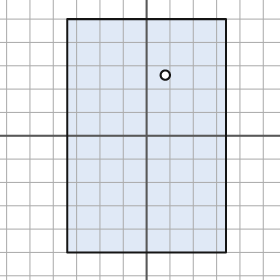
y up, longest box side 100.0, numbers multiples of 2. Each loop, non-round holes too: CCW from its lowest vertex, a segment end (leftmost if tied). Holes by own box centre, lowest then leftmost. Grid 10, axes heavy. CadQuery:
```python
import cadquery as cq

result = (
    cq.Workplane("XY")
    .moveTo(-34.0, -50.0)
    .lineTo(34.0, -50.0)
    .lineTo(34.0, 50.0)
    .lineTo(-34.0, 50.0)
    .close()
    .moveTo(8.0, 26.0)
    .circle(2.0)
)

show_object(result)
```